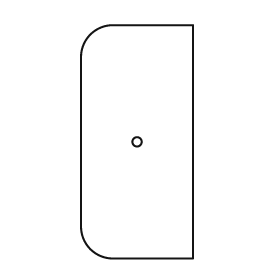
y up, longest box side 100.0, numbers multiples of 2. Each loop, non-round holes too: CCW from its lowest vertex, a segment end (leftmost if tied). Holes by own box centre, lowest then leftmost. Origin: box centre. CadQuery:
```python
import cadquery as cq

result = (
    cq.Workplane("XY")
    .moveTo(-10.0, -50.0)
    .lineTo(24.0, -50.0)
    .lineTo(24.0, 50.0)
    .lineTo(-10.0, 50.0)
    .threePointArc((-20.0, 46.0), (-24.0, 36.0))
    .lineTo(-24.0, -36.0)
    .threePointArc((-20.0, -46.0), (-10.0, -50.0))
    .close()
    .moveTo(0.0, 0.0)
    .circle(2.0)
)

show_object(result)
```